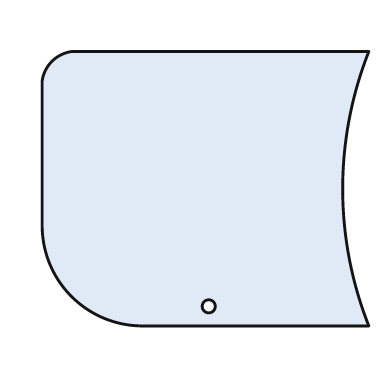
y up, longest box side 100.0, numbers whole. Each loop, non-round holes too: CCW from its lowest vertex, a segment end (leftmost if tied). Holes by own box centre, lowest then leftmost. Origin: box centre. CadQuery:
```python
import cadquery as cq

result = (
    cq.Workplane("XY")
    .moveTo(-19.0, -42.0)
    .lineTo(50.0, -42.0)
    .threePointArc((42.0, 0.0), (50.0, 42.0))
    .lineTo(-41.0, 42.0)
    .threePointArc((-47.0, 39.0), (-50.0, 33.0))
    .lineTo(-50.0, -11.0)
    .threePointArc((-41.0, -33.0), (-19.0, -42.0))
    .close()
    .moveTo(1.0, -36.0)
    .circle(2.0)
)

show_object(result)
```